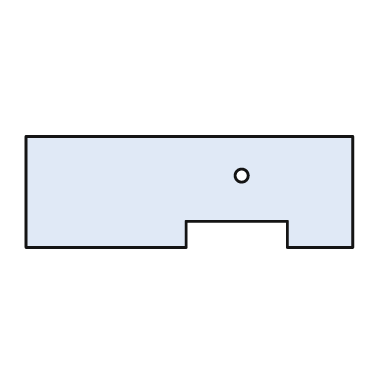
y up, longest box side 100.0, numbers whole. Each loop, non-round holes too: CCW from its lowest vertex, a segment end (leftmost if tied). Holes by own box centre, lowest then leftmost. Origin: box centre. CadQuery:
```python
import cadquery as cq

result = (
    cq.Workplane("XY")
    .moveTo(-50.0, -17.0)
    .lineTo(-1.0, -17.0)
    .lineTo(-1.0, -9.0)
    .lineTo(30.0, -9.0)
    .lineTo(30.0, -17.0)
    .lineTo(50.0, -17.0)
    .lineTo(50.0, 17.0)
    .lineTo(-50.0, 17.0)
    .close()
    .moveTo(16.0, 5.0)
    .circle(2.0)
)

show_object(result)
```